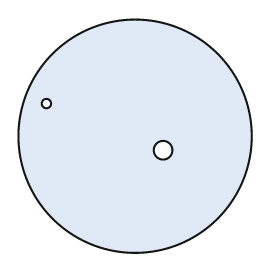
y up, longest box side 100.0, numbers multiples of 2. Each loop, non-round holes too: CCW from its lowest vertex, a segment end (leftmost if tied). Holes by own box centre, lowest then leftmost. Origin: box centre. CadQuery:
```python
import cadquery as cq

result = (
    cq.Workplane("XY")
    .moveTo(0.0, 0.0)
    .circle(50.0)
    .moveTo(12.0, -6.0)
    .circle(4.0)
    .moveTo(-38.0, 14.0)
    .circle(2.0)
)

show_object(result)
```